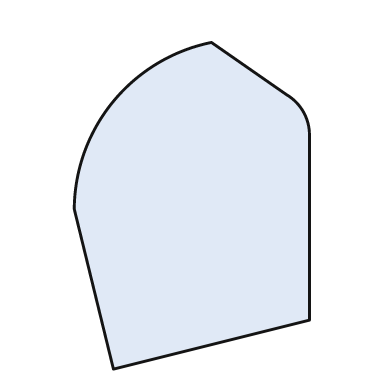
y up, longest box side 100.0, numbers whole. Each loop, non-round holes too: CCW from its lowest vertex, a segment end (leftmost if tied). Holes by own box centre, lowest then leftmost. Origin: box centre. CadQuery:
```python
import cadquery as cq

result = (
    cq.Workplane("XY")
    .moveTo(-24.0, -50.0)
    .lineTo(36.0, -35.0)
    .lineTo(36.0, 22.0)
    .threePointArc((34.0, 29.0), (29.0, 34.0))
    .lineTo(6.0, 50.0)
    .threePointArc((-24.0, 32.0), (-36.0, -1.0))
    .close()
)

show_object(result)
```